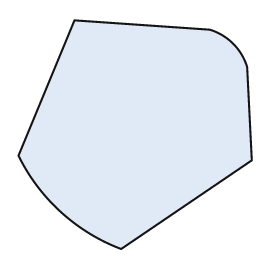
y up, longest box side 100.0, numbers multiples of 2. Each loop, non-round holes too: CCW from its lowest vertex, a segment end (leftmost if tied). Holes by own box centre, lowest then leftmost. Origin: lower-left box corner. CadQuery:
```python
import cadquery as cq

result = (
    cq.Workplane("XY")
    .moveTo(44.0, 0.0)
    .lineTo(100.0, 38.0)
    .lineTo(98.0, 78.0)
    .threePointArc((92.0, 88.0), (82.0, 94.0))
    .lineTo(24.0, 98.0)
    .lineTo(0.0, 40.0)
    .threePointArc((18.0, 16.0), (44.0, 0.0))
    .close()
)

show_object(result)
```